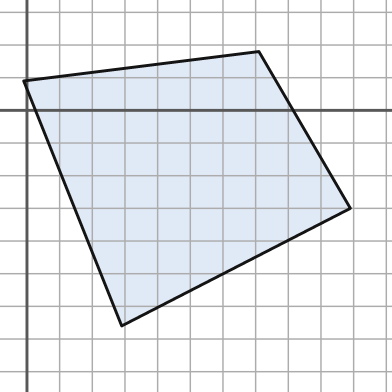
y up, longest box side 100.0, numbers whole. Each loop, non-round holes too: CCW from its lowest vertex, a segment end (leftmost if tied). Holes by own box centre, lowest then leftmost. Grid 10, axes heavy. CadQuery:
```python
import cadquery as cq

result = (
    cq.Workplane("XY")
    .moveTo(29.0, -66.0)
    .lineTo(99.0, -30.0)
    .lineTo(71.0, 18.0)
    .lineTo(-1.0, 9.0)
    .close()
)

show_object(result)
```